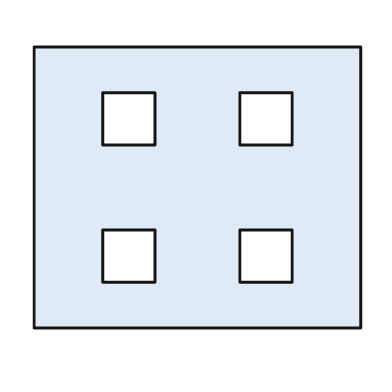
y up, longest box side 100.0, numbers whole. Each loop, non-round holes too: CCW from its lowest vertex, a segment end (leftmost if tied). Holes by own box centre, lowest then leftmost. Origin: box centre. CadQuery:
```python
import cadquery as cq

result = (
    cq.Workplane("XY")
    .moveTo(-50.0, -43.0)
    .lineTo(50.0, -43.0)
    .lineTo(50.0, 43.0)
    .lineTo(-50.0, 43.0)
    .close()
    .moveTo(-29.0, -29.0)
    .lineTo(-13.0, -29.0)
    .lineTo(-13.0, -13.0)
    .lineTo(-29.0, -13.0)
    .close()
    .moveTo(13.0, -29.0)
    .lineTo(29.0, -29.0)
    .lineTo(29.0, -13.0)
    .lineTo(13.0, -13.0)
    .close()
    .moveTo(-29.0, 13.0)
    .lineTo(-13.0, 13.0)
    .lineTo(-13.0, 29.0)
    .lineTo(-29.0, 29.0)
    .close()
    .moveTo(13.0, 13.0)
    .lineTo(29.0, 13.0)
    .lineTo(29.0, 29.0)
    .lineTo(13.0, 29.0)
    .close()
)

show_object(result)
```